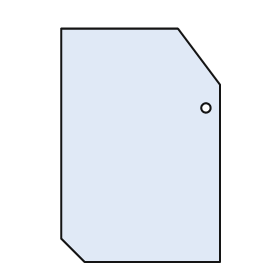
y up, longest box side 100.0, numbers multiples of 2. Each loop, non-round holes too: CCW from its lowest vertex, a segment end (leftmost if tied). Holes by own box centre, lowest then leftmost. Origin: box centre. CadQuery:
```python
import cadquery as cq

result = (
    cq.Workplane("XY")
    .moveTo(-24.0, -50.0)
    .lineTo(34.0, -50.0)
    .lineTo(34.0, 26.0)
    .lineTo(16.0, 50.0)
    .lineTo(-34.0, 50.0)
    .lineTo(-34.0, -40.0)
    .close()
    .moveTo(28.0, 16.0)
    .circle(2.0)
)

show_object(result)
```